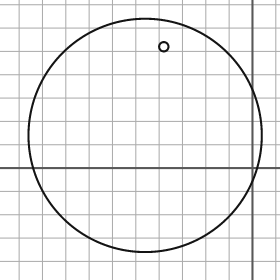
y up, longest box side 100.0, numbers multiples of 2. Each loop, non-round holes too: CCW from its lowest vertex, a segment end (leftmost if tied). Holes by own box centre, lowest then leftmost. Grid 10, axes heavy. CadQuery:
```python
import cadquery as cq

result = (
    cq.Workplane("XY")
    .moveTo(-46.0, 14.0)
    .circle(50.0)
    .moveTo(-38.0, 52.0)
    .circle(2.0)
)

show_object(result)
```